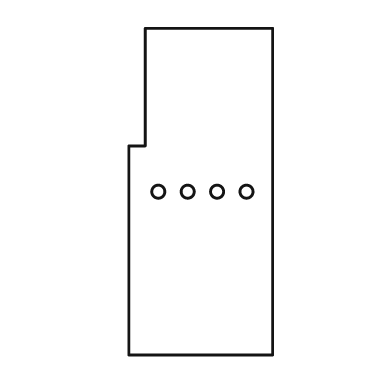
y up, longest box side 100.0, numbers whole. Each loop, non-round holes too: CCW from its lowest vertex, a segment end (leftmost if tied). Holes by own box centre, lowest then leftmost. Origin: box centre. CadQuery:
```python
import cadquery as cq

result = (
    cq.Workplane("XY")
    .moveTo(-22.0, -50.0)
    .lineTo(22.0, -50.0)
    .lineTo(22.0, 50.0)
    .lineTo(-17.0, 50.0)
    .lineTo(-17.0, 14.0)
    .lineTo(-22.0, 14.0)
    .close()
    .moveTo(-13.0, 0.0)
    .circle(2.0)
    .moveTo(-4.0, 0.0)
    .circle(2.0)
    .moveTo(5.0, 0.0)
    .circle(2.0)
    .moveTo(14.0, 0.0)
    .circle(2.0)
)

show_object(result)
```